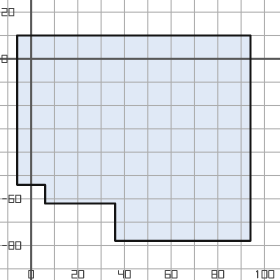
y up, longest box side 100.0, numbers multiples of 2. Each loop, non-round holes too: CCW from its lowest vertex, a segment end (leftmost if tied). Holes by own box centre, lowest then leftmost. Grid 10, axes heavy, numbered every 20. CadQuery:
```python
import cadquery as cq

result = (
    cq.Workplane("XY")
    .moveTo(36.0, -78.0)
    .lineTo(94.0, -78.0)
    .lineTo(94.0, 10.0)
    .lineTo(-6.0, 10.0)
    .lineTo(-6.0, -54.0)
    .lineTo(6.0, -54.0)
    .lineTo(6.0, -62.0)
    .lineTo(36.0, -62.0)
    .close()
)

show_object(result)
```